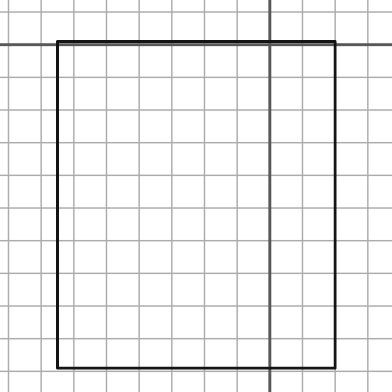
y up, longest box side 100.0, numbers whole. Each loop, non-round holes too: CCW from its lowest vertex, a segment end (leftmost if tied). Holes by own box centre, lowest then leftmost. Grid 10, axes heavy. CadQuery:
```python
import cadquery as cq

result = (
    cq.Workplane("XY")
    .moveTo(-65.0, -99.0)
    .lineTo(20.0, -99.0)
    .lineTo(20.0, 1.0)
    .lineTo(-65.0, 1.0)
    .close()
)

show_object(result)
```